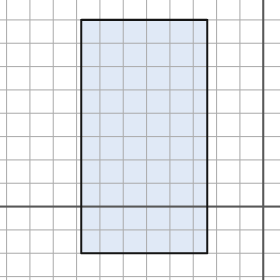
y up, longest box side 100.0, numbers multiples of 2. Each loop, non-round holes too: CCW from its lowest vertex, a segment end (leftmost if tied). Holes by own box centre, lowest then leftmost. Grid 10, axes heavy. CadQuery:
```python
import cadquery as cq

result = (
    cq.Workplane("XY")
    .moveTo(-78.0, -20.0)
    .lineTo(-24.0, -20.0)
    .lineTo(-24.0, 80.0)
    .lineTo(-78.0, 80.0)
    .close()
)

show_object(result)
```